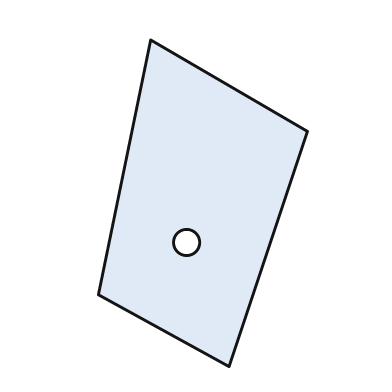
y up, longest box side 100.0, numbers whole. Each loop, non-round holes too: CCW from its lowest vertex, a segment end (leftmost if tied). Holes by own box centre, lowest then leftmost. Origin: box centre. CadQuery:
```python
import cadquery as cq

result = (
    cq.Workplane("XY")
    .moveTo(8.0, -50.0)
    .lineTo(32.0, 22.0)
    .lineTo(-16.0, 50.0)
    .lineTo(-32.0, -28.0)
    .close()
    .moveTo(-5.0, -12.0)
    .circle(4.0)
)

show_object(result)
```